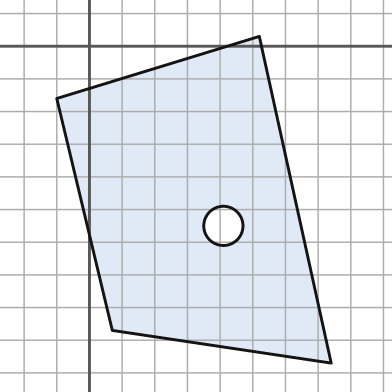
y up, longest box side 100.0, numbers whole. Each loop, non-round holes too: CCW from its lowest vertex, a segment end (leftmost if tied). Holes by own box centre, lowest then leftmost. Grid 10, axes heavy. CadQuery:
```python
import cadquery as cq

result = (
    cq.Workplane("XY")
    .moveTo(74.0, -97.0)
    .lineTo(52.0, 3.0)
    .lineTo(-10.0, -16.0)
    .lineTo(7.0, -87.0)
    .close()
    .moveTo(41.0, -55.0)
    .circle(6.0)
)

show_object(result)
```